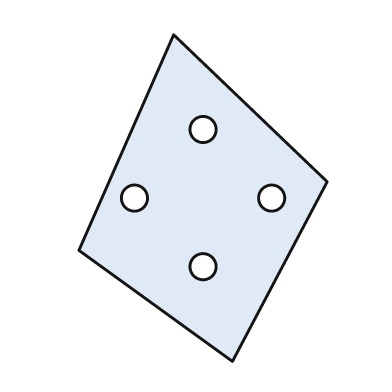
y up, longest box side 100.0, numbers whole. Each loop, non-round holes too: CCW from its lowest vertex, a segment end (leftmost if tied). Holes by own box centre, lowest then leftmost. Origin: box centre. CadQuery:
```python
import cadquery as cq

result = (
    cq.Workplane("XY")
    .moveTo(9.0, -50.0)
    .lineTo(38.0, 5.0)
    .lineTo(-9.0, 50.0)
    .lineTo(-38.0, -16.0)
    .close()
    .moveTo(0.0, -21.0)
    .circle(4.0)
    .moveTo(-21.0, 0.0)
    .circle(4.0)
    .moveTo(21.0, 0.0)
    .circle(4.0)
    .moveTo(0.0, 21.0)
    .circle(4.0)
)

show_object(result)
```